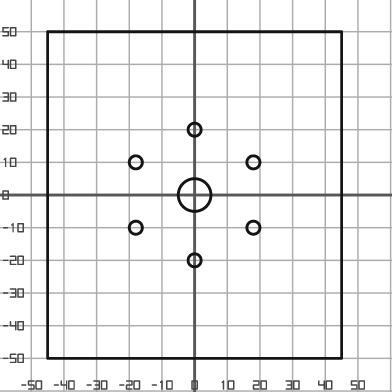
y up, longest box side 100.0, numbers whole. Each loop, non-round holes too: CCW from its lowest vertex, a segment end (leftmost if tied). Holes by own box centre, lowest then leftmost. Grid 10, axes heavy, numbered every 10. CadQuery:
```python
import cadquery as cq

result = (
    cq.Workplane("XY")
    .moveTo(-45.0, -50.0)
    .lineTo(45.0, -50.0)
    .lineTo(45.0, 50.0)
    .lineTo(-45.0, 50.0)
    .close()
    .moveTo(0.0, -20.0)
    .circle(2.0)
    .moveTo(-18.0, -10.0)
    .circle(2.0)
    .moveTo(18.0, -10.0)
    .circle(2.0)
    .moveTo(0.0, 0.0)
    .circle(5.0)
    .moveTo(-18.0, 10.0)
    .circle(2.0)
    .moveTo(18.0, 10.0)
    .circle(2.0)
    .moveTo(0.0, 20.0)
    .circle(2.0)
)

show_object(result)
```